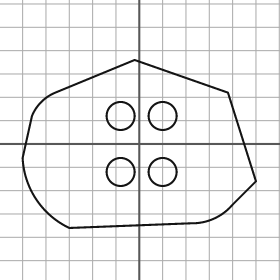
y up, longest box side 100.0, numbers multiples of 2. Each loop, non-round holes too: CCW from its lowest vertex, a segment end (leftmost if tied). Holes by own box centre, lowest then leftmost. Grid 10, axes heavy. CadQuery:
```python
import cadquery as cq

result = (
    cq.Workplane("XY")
    .moveTo(-30.0, -36.0)
    .lineTo(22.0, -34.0)
    .threePointArc((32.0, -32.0), (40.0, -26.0))
    .lineTo(50.0, -16.0)
    .lineTo(38.0, 22.0)
    .lineTo(-2.0, 36.0)
    .lineTo(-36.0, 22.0)
    .threePointArc((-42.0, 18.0), (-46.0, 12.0))
    .lineTo(-50.0, -6.0)
    .threePointArc((-44.0, -24.0), (-30.0, -36.0))
    .close()
    .moveTo(-8.0, -12.0)
    .circle(6.0)
    .moveTo(10.0, -12.0)
    .circle(6.0)
    .moveTo(-8.0, 12.0)
    .circle(6.0)
    .moveTo(10.0, 12.0)
    .circle(6.0)
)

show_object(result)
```